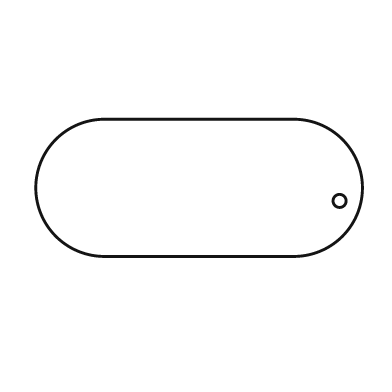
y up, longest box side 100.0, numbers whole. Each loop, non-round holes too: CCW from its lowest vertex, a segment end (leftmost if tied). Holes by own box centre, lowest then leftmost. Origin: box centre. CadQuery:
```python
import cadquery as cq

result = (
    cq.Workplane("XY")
    .moveTo(-29.0, -21.0)
    .lineTo(29.0, -21.0)
    .threePointArc((50.0, 0.0), (29.0, 21.0))
    .lineTo(-29.0, 21.0)
    .threePointArc((-50.0, 0.0), (-29.0, -21.0))
    .close()
    .moveTo(43.0, -4.0)
    .circle(2.0)
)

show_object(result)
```